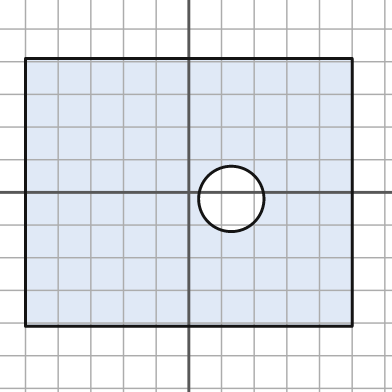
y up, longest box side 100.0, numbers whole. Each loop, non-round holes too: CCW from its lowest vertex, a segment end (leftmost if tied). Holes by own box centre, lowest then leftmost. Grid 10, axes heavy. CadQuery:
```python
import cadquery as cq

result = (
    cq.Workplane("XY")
    .moveTo(-50.0, -41.0)
    .lineTo(50.0, -41.0)
    .lineTo(50.0, 41.0)
    .lineTo(-50.0, 41.0)
    .close()
    .moveTo(13.0, -2.0)
    .circle(10.0)
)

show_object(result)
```